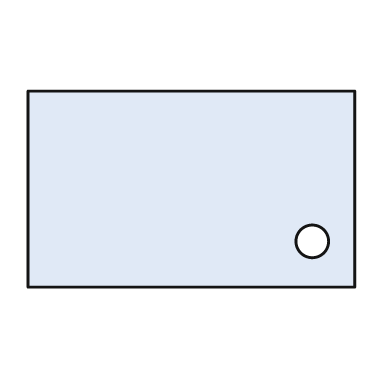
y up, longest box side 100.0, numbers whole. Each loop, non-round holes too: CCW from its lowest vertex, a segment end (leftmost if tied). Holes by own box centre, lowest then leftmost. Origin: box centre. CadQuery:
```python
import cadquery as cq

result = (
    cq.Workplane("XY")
    .moveTo(-50.0, -30.0)
    .lineTo(50.0, -30.0)
    .lineTo(50.0, 30.0)
    .lineTo(-50.0, 30.0)
    .close()
    .moveTo(37.0, -16.0)
    .circle(5.0)
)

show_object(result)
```